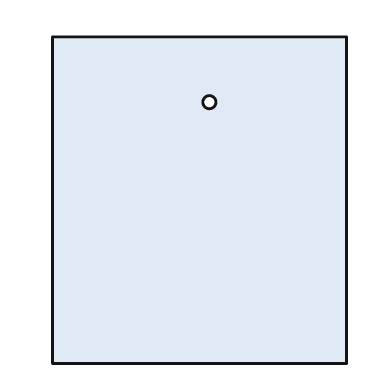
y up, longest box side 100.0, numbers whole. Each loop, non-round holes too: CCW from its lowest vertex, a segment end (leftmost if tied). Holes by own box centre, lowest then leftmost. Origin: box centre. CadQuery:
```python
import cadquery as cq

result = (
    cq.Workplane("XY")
    .moveTo(-45.0, -50.0)
    .lineTo(45.0, -50.0)
    .lineTo(45.0, 50.0)
    .lineTo(-45.0, 50.0)
    .close()
    .moveTo(3.0, 30.0)
    .circle(2.0)
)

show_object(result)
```